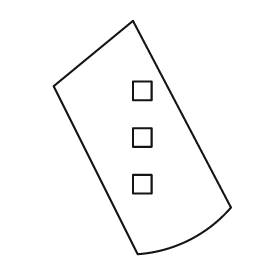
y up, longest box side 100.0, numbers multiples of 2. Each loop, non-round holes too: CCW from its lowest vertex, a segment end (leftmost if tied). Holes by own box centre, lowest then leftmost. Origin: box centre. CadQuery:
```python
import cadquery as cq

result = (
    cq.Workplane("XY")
    .moveTo(-2.0, -50.0)
    .threePointArc((20.0, -44.0), (38.0, -30.0))
    .lineTo(-4.0, 50.0)
    .lineTo(-38.0, 22.0)
    .close()
    .moveTo(-4.0, -24.0)
    .lineTo(4.0, -24.0)
    .lineTo(4.0, -16.0)
    .lineTo(-4.0, -16.0)
    .close()
    .moveTo(-4.0, -4.0)
    .lineTo(4.0, -4.0)
    .lineTo(4.0, 4.0)
    .lineTo(-4.0, 4.0)
    .close()
    .moveTo(-4.0, 16.0)
    .lineTo(4.0, 16.0)
    .lineTo(4.0, 24.0)
    .lineTo(-4.0, 24.0)
    .close()
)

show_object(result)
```